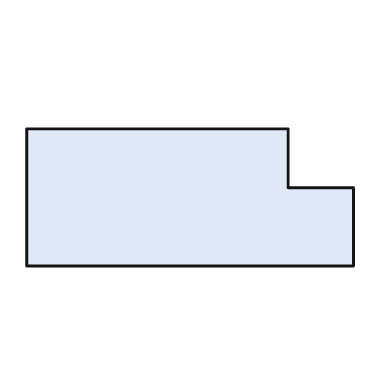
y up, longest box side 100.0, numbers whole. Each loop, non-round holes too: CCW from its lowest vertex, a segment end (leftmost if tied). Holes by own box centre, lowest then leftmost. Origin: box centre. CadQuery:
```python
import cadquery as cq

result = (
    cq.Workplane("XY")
    .moveTo(-50.0, -21.0)
    .lineTo(50.0, -21.0)
    .lineTo(50.0, 3.0)
    .lineTo(30.0, 3.0)
    .lineTo(30.0, 21.0)
    .lineTo(-50.0, 21.0)
    .close()
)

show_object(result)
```